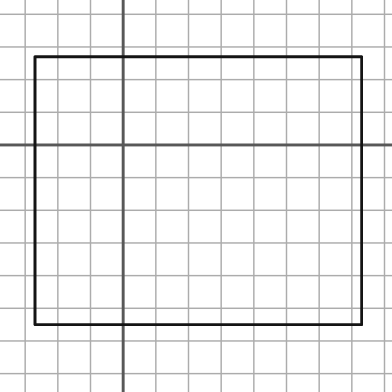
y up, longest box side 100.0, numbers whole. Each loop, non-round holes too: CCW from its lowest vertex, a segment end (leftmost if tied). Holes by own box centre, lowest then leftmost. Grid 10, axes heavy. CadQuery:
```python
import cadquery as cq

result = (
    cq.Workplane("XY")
    .moveTo(-27.0, -55.0)
    .lineTo(73.0, -55.0)
    .lineTo(73.0, 27.0)
    .lineTo(-27.0, 27.0)
    .close()
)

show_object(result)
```